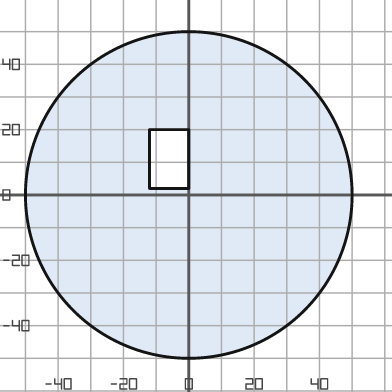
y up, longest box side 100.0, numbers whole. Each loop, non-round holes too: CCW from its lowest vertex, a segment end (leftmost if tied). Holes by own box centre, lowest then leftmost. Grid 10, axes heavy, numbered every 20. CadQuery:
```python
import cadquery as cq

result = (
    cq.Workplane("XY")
    .moveTo(0.0, 0.0)
    .circle(50.0)
    .moveTo(-12.0, 2.0)
    .lineTo(0.0, 2.0)
    .lineTo(0.0, 20.0)
    .lineTo(-12.0, 20.0)
    .close()
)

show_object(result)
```